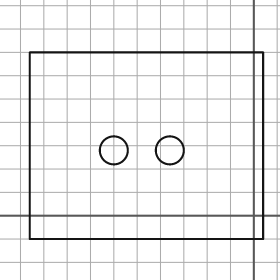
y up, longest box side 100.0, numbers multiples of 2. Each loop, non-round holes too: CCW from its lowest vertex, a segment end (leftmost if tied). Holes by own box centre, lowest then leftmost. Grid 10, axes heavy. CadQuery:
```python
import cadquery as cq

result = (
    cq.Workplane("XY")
    .moveTo(-96.0, -10.0)
    .lineTo(4.0, -10.0)
    .lineTo(4.0, 70.0)
    .lineTo(-96.0, 70.0)
    .close()
    .moveTo(-60.0, 28.0)
    .circle(6.0)
    .moveTo(-36.0, 28.0)
    .circle(6.0)
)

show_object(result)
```